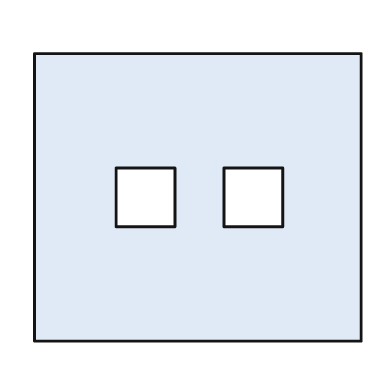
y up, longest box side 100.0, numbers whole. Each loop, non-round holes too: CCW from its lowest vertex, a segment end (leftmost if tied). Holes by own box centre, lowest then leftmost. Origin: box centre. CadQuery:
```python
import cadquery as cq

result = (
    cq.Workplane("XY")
    .moveTo(-50.0, -44.0)
    .lineTo(50.0, -44.0)
    .lineTo(50.0, 44.0)
    .lineTo(-50.0, 44.0)
    .close()
    .moveTo(-25.0, -9.0)
    .lineTo(-7.0, -9.0)
    .lineTo(-7.0, 9.0)
    .lineTo(-25.0, 9.0)
    .close()
    .moveTo(8.0, -9.0)
    .lineTo(26.0, -9.0)
    .lineTo(26.0, 9.0)
    .lineTo(8.0, 9.0)
    .close()
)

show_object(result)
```